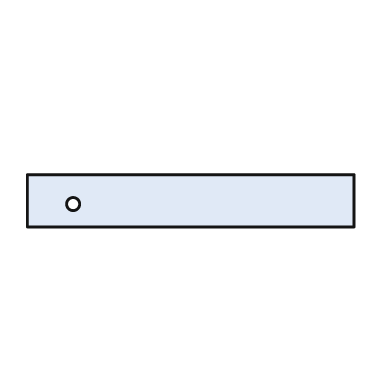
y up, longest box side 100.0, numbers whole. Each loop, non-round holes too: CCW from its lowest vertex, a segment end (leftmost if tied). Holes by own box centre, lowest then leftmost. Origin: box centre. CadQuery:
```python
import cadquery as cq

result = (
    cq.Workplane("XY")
    .moveTo(-50.0, -8.0)
    .lineTo(50.0, -8.0)
    .lineTo(50.0, 8.0)
    .lineTo(-50.0, 8.0)
    .close()
    .moveTo(-36.0, -1.0)
    .circle(2.0)
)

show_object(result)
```